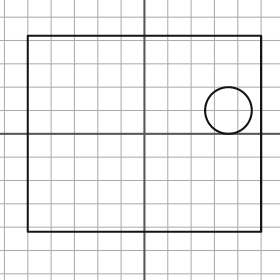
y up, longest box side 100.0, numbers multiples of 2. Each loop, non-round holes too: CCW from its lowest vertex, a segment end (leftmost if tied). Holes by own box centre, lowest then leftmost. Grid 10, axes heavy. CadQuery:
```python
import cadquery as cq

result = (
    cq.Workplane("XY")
    .moveTo(-50.0, -42.0)
    .lineTo(50.0, -42.0)
    .lineTo(50.0, 42.0)
    .lineTo(-50.0, 42.0)
    .close()
    .moveTo(36.0, 10.0)
    .circle(10.0)
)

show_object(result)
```